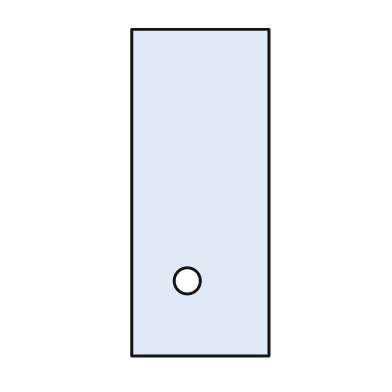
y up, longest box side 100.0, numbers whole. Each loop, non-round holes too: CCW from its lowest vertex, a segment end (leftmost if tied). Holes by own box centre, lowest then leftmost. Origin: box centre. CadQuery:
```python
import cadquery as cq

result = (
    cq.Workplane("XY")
    .moveTo(-21.0, -50.0)
    .lineTo(21.0, -50.0)
    .lineTo(21.0, 50.0)
    .lineTo(-21.0, 50.0)
    .close()
    .moveTo(-4.0, -27.0)
    .circle(4.0)
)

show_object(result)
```